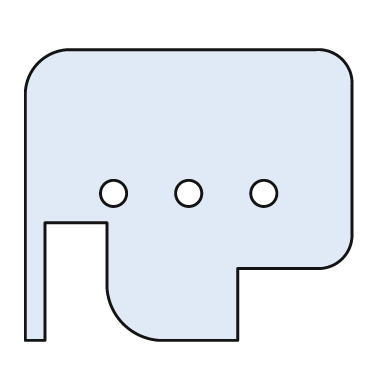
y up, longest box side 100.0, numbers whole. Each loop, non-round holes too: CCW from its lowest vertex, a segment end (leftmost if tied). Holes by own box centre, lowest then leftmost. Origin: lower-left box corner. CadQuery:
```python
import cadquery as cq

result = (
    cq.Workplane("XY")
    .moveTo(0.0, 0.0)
    .lineTo(6.0, 0.0)
    .lineTo(6.0, 36.0)
    .lineTo(25.0, 36.0)
    .lineTo(25.0, 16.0)
    .threePointArc((30.0, 5.0), (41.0, 0.0))
    .lineTo(65.0, 0.0)
    .lineTo(65.0, 22.0)
    .lineTo(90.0, 22.0)
    .threePointArc((97.0, 25.0), (100.0, 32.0))
    .lineTo(100.0, 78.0)
    .threePointArc((97.0, 86.0), (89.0, 89.0))
    .lineTo(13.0, 89.0)
    .threePointArc((4.0, 85.0), (0.0, 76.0))
    .close()
    .moveTo(27.0, 45.0)
    .circle(4.0)
    .moveTo(50.0, 45.0)
    .circle(4.0)
    .moveTo(73.0, 45.0)
    .circle(4.0)
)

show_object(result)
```